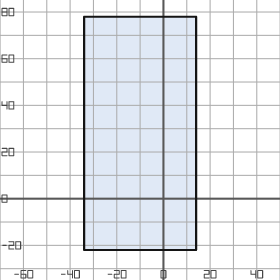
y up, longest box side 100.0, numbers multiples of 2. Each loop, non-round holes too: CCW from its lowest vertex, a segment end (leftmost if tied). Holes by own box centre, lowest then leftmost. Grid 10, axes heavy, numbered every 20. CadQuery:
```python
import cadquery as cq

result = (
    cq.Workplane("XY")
    .moveTo(-34.0, -22.0)
    .lineTo(14.0, -22.0)
    .lineTo(14.0, 78.0)
    .lineTo(-34.0, 78.0)
    .close()
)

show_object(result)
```